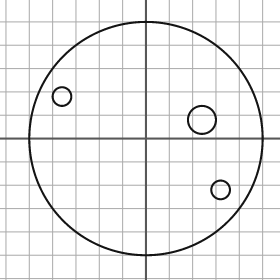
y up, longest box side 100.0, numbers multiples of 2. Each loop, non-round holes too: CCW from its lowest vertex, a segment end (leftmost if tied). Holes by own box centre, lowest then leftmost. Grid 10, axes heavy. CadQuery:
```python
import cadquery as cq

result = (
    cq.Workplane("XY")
    .moveTo(0.0, 0.0)
    .circle(50.0)
    .moveTo(32.0, -22.0)
    .circle(4.0)
    .moveTo(24.0, 8.0)
    .circle(6.0)
    .moveTo(-36.0, 18.0)
    .circle(4.0)
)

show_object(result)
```